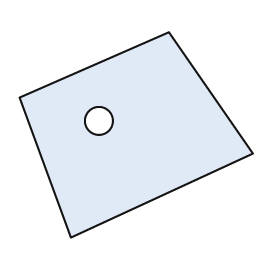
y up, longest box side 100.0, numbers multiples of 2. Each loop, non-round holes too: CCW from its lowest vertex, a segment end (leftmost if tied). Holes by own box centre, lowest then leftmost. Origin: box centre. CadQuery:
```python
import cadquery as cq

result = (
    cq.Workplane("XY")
    .moveTo(-28.0, -44.0)
    .lineTo(50.0, -8.0)
    .lineTo(14.0, 44.0)
    .lineTo(-50.0, 16.0)
    .close()
    .moveTo(-16.0, 6.0)
    .circle(6.0)
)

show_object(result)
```